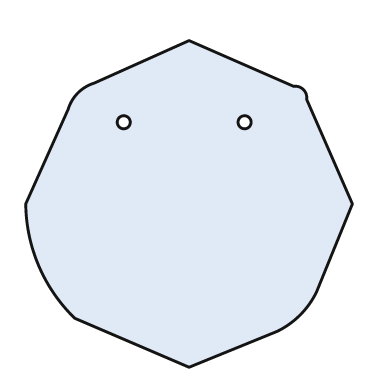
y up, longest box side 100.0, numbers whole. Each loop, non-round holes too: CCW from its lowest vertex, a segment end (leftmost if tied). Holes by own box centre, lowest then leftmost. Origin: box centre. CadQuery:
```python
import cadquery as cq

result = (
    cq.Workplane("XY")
    .moveTo(0.0, -50.0)
    .lineTo(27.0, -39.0)
    .threePointArc((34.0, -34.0), (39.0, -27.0))
    .lineTo(50.0, 0.0)
    .lineTo(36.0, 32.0)
    .threePointArc((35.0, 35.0), (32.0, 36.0))
    .lineTo(0.0, 50.0)
    .lineTo(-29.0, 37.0)
    .threePointArc((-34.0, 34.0), (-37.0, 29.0))
    .lineTo(-50.0, 0.0)
    .threePointArc((-46.0, -19.0), (-35.0, -35.0))
    .close()
    .moveTo(-20.0, 25.0)
    .circle(2.0)
    .moveTo(17.0, 25.0)
    .circle(2.0)
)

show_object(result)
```